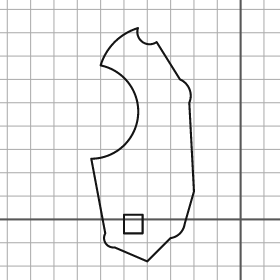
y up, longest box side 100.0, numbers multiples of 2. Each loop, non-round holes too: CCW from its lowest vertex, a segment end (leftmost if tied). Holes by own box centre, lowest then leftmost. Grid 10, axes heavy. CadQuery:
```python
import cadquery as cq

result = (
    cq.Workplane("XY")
    .moveTo(-40.0, -18.0)
    .lineTo(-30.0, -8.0)
    .threePointArc((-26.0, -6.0), (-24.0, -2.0))
    .lineTo(-20.0, 12.0)
    .lineTo(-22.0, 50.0)
    .threePointArc((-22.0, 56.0), (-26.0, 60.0))
    .lineTo(-36.0, 76.0)
    .threePointArc((-42.0, 76.0), (-44.0, 82.0))
    .threePointArc((-54.0, 76.0), (-60.0, 66.0))
    .threePointArc((-44.0, 44.0), (-64.0, 26.0))
    .lineTo(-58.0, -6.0)
    .threePointArc((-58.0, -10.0), (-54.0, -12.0))
    .close()
    .moveTo(-50.0, -6.0)
    .lineTo(-42.0, -6.0)
    .lineTo(-42.0, 2.0)
    .lineTo(-50.0, 2.0)
    .close()
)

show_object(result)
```